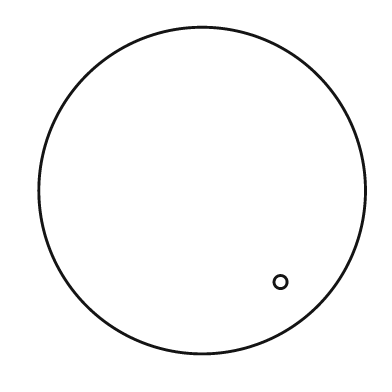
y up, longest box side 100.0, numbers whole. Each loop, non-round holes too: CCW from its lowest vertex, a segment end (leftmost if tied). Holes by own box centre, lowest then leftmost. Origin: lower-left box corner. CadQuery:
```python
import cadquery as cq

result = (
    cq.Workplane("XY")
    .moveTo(50.0, 50.0)
    .circle(50.0)
    .moveTo(74.0, 22.0)
    .circle(2.0)
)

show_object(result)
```